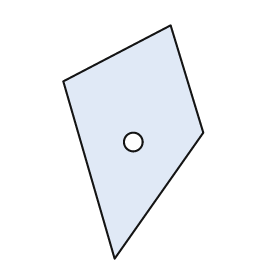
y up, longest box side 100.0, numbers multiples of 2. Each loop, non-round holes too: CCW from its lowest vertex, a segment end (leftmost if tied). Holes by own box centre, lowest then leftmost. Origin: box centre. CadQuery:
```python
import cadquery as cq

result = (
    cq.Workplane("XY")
    .moveTo(-8.0, -50.0)
    .lineTo(30.0, 4.0)
    .lineTo(16.0, 50.0)
    .lineTo(-30.0, 26.0)
    .close()
    .moveTo(0.0, 0.0)
    .circle(4.0)
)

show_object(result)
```